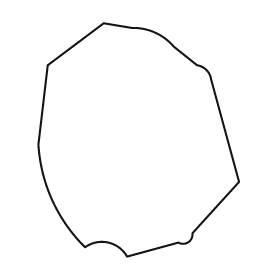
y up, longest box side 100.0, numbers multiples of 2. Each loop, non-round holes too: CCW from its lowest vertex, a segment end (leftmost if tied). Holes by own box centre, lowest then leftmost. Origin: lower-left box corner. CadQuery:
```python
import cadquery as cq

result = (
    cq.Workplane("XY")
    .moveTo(38.0, 0.0)
    .lineTo(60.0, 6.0)
    .threePointArc((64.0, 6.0), (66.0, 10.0))
    .lineTo(86.0, 32.0)
    .lineTo(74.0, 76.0)
    .threePointArc((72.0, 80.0), (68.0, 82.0))
    .lineTo(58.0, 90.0)
    .threePointArc((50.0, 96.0), (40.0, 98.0))
    .lineTo(28.0, 100.0)
    .lineTo(4.0, 82.0)
    .lineTo(0.0, 48.0)
    .threePointArc((6.0, 24.0), (20.0, 4.0))
    .threePointArc((30.0, 6.0), (38.0, 0.0))
    .close()
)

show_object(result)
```